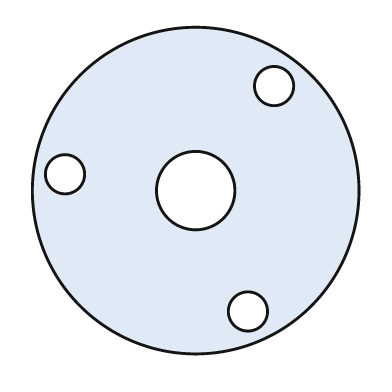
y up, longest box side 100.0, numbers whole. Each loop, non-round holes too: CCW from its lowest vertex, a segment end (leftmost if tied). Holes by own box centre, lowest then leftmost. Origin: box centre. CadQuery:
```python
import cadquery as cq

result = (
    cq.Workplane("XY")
    .moveTo(0.0, 0.0)
    .circle(50.0)
    .moveTo(16.0, -37.0)
    .circle(6.0)
    .moveTo(0.0, 0.0)
    .circle(12.0)
    .moveTo(-40.0, 5.0)
    .circle(6.0)
    .moveTo(24.0, 32.0)
    .circle(6.0)
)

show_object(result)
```